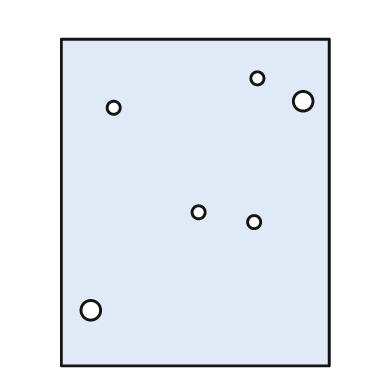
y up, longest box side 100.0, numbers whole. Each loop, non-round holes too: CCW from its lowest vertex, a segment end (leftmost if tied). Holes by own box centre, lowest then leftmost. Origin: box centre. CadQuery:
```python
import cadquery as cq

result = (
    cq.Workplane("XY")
    .moveTo(-41.0, -50.0)
    .lineTo(41.0, -50.0)
    .lineTo(41.0, 50.0)
    .lineTo(-41.0, 50.0)
    .close()
    .moveTo(-32.0, -33.0)
    .circle(3.0)
    .moveTo(18.0, -6.0)
    .circle(2.0)
    .moveTo(1.0, -3.0)
    .circle(2.0)
    .moveTo(-25.0, 29.0)
    .circle(2.0)
    .moveTo(33.0, 31.0)
    .circle(3.0)
    .moveTo(19.0, 38.0)
    .circle(2.0)
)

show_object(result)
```